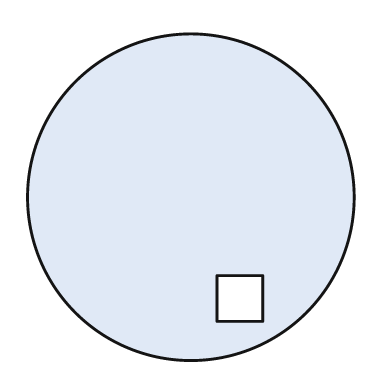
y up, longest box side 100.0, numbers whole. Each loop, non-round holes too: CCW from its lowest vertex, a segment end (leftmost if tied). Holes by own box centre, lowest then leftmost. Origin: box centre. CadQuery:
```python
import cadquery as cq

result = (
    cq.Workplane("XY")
    .moveTo(0.0, 0.0)
    .circle(50.0)
    .moveTo(8.0, -38.0)
    .lineTo(22.0, -38.0)
    .lineTo(22.0, -24.0)
    .lineTo(8.0, -24.0)
    .close()
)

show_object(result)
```